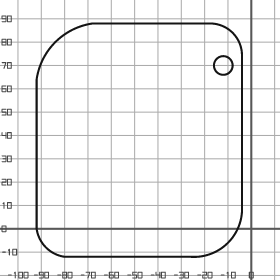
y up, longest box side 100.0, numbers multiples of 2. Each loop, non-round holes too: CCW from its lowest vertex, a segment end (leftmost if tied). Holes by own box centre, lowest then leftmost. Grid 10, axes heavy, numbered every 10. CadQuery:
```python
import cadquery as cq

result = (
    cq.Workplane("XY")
    .moveTo(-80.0, -12.0)
    .lineTo(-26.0, -12.0)
    .threePointArc((-10.0, -6.0), (-4.0, 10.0))
    .lineTo(-4.0, 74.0)
    .threePointArc((-8.0, 84.0), (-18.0, 88.0))
    .lineTo(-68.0, 88.0)
    .threePointArc((-84.0, 80.0), (-92.0, 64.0))
    .lineTo(-92.0, 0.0)
    .threePointArc((-88.0, -8.0), (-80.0, -12.0))
    .close()
    .moveTo(-12.0, 70.0)
    .circle(4.0)
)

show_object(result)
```